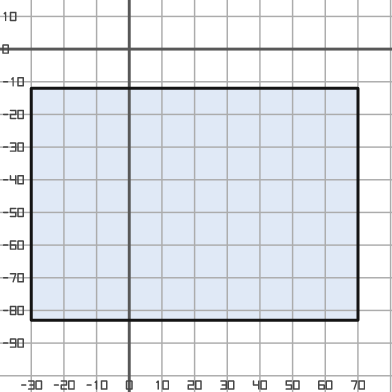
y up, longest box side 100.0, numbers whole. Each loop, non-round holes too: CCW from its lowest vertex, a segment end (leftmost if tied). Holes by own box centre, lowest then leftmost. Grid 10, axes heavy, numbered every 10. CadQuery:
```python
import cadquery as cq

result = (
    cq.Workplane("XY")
    .moveTo(-30.0, -83.0)
    .lineTo(70.0, -83.0)
    .lineTo(70.0, -12.0)
    .lineTo(-30.0, -12.0)
    .close()
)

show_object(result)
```